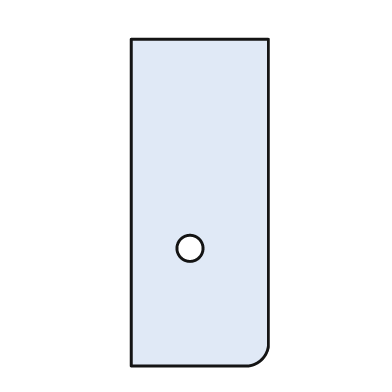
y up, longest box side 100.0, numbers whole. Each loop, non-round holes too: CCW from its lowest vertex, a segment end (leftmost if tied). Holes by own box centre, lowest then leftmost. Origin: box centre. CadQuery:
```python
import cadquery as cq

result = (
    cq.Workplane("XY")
    .moveTo(-21.0, -50.0)
    .lineTo(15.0, -50.0)
    .threePointArc((19.0, -48.0), (21.0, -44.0))
    .lineTo(21.0, 50.0)
    .lineTo(-21.0, 50.0)
    .close()
    .moveTo(-3.0, -14.0)
    .circle(4.0)
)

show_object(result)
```